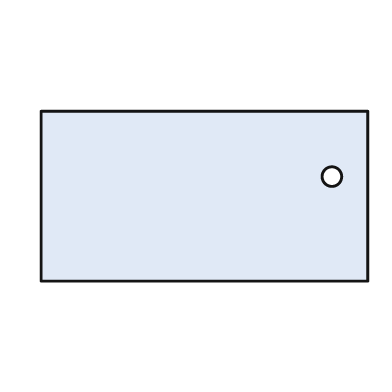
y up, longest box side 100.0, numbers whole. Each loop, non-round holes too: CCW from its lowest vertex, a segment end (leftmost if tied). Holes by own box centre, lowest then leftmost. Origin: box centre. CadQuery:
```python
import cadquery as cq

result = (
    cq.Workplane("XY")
    .moveTo(-50.0, -26.0)
    .lineTo(50.0, -26.0)
    .lineTo(50.0, 26.0)
    .lineTo(-50.0, 26.0)
    .close()
    .moveTo(39.0, 6.0)
    .circle(3.0)
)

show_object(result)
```